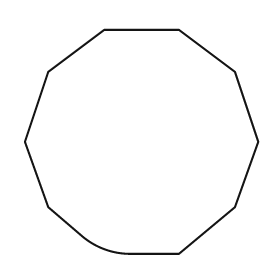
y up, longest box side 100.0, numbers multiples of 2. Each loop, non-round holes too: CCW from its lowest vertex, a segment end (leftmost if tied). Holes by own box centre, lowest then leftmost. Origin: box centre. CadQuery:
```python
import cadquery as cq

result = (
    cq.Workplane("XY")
    .moveTo(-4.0, -48.0)
    .lineTo(16.0, -48.0)
    .lineTo(40.0, -28.0)
    .lineTo(50.0, 0.0)
    .lineTo(40.0, 30.0)
    .lineTo(16.0, 48.0)
    .lineTo(-16.0, 48.0)
    .lineTo(-40.0, 30.0)
    .lineTo(-50.0, 0.0)
    .lineTo(-40.0, -28.0)
    .lineTo(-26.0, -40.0)
    .threePointArc((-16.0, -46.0), (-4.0, -48.0))
    .close()
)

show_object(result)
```